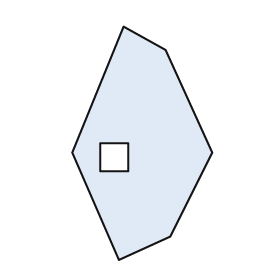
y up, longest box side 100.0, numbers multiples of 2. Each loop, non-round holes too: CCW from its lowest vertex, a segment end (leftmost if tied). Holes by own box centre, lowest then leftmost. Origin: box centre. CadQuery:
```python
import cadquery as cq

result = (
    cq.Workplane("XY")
    .moveTo(-10.0, -50.0)
    .lineTo(12.0, -40.0)
    .lineTo(30.0, -4.0)
    .lineTo(10.0, 40.0)
    .lineTo(-8.0, 50.0)
    .lineTo(-30.0, -4.0)
    .close()
    .moveTo(-18.0, -12.0)
    .lineTo(-6.0, -12.0)
    .lineTo(-6.0, 0.0)
    .lineTo(-18.0, 0.0)
    .close()
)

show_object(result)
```